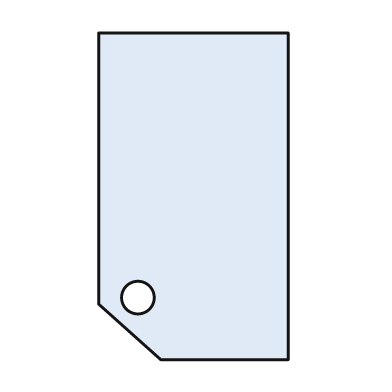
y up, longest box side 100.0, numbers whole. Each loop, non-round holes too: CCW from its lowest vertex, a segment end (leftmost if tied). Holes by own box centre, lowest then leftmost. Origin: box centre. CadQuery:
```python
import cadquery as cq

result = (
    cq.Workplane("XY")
    .moveTo(-10.0, -50.0)
    .lineTo(29.0, -50.0)
    .lineTo(29.0, 50.0)
    .lineTo(-29.0, 50.0)
    .lineTo(-29.0, -33.0)
    .close()
    .moveTo(-17.0, -31.0)
    .circle(5.0)
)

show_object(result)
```